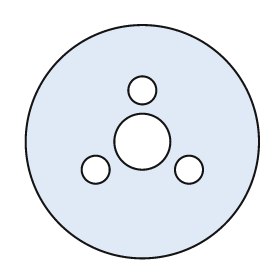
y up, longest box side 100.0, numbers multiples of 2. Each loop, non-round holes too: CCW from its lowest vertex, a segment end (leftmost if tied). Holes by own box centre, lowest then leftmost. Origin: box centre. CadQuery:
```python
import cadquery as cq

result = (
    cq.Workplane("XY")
    .moveTo(0.0, 0.0)
    .circle(50.0)
    .moveTo(-20.0, -12.0)
    .circle(6.0)
    .moveTo(20.0, -12.0)
    .circle(6.0)
    .moveTo(0.0, 0.0)
    .circle(12.0)
    .moveTo(0.0, 22.0)
    .circle(6.0)
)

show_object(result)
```